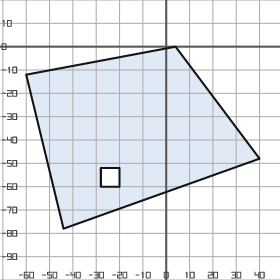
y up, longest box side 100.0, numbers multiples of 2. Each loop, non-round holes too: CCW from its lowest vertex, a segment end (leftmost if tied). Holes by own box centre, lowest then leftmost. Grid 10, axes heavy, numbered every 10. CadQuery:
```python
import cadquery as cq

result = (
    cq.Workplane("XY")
    .moveTo(-44.0, -78.0)
    .lineTo(40.0, -48.0)
    .lineTo(4.0, 0.0)
    .lineTo(-60.0, -12.0)
    .close()
    .moveTo(-28.0, -60.0)
    .lineTo(-20.0, -60.0)
    .lineTo(-20.0, -52.0)
    .lineTo(-28.0, -52.0)
    .close()
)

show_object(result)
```